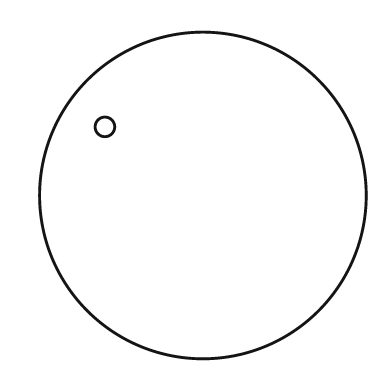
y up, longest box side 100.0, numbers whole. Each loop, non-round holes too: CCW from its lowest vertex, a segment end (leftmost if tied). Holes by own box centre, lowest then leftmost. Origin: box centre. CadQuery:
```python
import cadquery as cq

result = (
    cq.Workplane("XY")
    .moveTo(0.0, 0.0)
    .circle(50.0)
    .moveTo(-30.0, 21.0)
    .circle(3.0)
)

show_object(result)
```